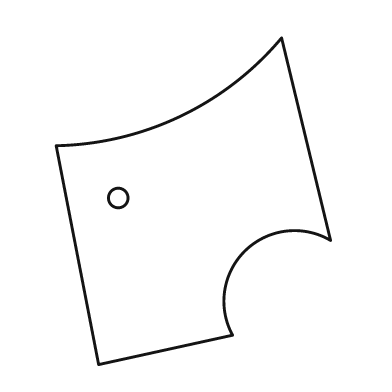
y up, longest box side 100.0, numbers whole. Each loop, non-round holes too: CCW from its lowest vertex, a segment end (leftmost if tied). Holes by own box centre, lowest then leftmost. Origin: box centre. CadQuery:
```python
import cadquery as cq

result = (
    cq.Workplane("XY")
    .moveTo(-29.0, -50.0)
    .lineTo(12.0, -41.0)
    .threePointArc((16.0, -15.0), (42.0, -12.0))
    .lineTo(27.0, 50.0)
    .threePointArc((-4.0, 26.0), (-42.0, 17.0))
    .close()
    .moveTo(-23.0, 1.0)
    .circle(3.0)
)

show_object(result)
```